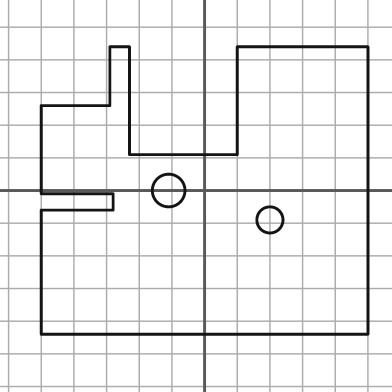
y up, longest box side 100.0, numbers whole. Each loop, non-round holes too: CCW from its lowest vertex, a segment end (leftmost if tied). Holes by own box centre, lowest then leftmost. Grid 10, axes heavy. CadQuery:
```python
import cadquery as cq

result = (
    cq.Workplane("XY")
    .moveTo(-50.0, -44.0)
    .lineTo(50.0, -44.0)
    .lineTo(50.0, 44.0)
    .lineTo(10.0, 44.0)
    .lineTo(10.0, 11.0)
    .lineTo(-23.0, 11.0)
    .lineTo(-23.0, 44.0)
    .lineTo(-29.0, 44.0)
    .lineTo(-29.0, 26.0)
    .lineTo(-50.0, 26.0)
    .lineTo(-50.0, -1.0)
    .lineTo(-28.0, -1.0)
    .lineTo(-28.0, -6.0)
    .lineTo(-50.0, -6.0)
    .close()
    .moveTo(20.0, -9.0)
    .circle(4.0)
    .moveTo(-11.0, 0.0)
    .circle(5.0)
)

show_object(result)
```